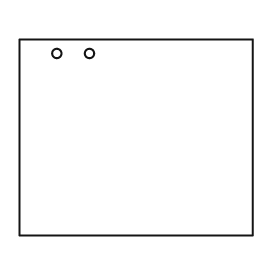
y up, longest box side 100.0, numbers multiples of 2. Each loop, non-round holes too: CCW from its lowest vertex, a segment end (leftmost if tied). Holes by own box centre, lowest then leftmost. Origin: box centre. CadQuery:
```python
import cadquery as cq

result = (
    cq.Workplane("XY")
    .moveTo(-50.0, -42.0)
    .lineTo(50.0, -42.0)
    .lineTo(50.0, 42.0)
    .lineTo(-50.0, 42.0)
    .close()
    .moveTo(-34.0, 36.0)
    .circle(2.0)
    .moveTo(-20.0, 36.0)
    .circle(2.0)
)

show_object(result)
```